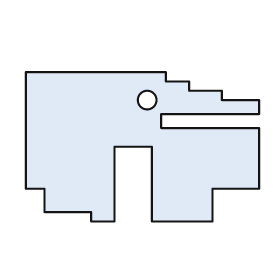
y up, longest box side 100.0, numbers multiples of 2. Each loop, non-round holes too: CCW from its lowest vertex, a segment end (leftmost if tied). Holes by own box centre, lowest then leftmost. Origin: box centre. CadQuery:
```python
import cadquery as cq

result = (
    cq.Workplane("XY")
    .moveTo(-22.0, -32.0)
    .lineTo(-12.0, -32.0)
    .lineTo(-12.0, 0.0)
    .lineTo(4.0, 0.0)
    .lineTo(4.0, -32.0)
    .lineTo(30.0, -32.0)
    .lineTo(30.0, -18.0)
    .lineTo(50.0, -18.0)
    .lineTo(50.0, 8.0)
    .lineTo(8.0, 8.0)
    .lineTo(8.0, 14.0)
    .lineTo(50.0, 14.0)
    .lineTo(50.0, 20.0)
    .lineTo(34.0, 20.0)
    .lineTo(34.0, 24.0)
    .lineTo(20.0, 24.0)
    .lineTo(20.0, 28.0)
    .lineTo(10.0, 28.0)
    .lineTo(10.0, 32.0)
    .lineTo(-50.0, 32.0)
    .lineTo(-50.0, -18.0)
    .lineTo(-42.0, -18.0)
    .lineTo(-42.0, -28.0)
    .lineTo(-22.0, -28.0)
    .close()
    .moveTo(2.0, 20.0)
    .circle(4.0)
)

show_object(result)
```